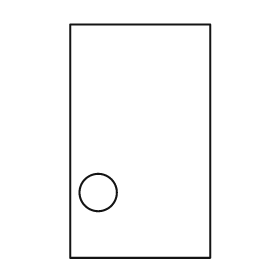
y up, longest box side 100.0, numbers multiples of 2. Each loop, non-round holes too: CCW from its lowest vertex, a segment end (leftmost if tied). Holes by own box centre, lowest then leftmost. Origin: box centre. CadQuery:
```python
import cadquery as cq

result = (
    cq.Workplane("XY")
    .moveTo(-30.0, -50.0)
    .lineTo(30.0, -50.0)
    .lineTo(30.0, 50.0)
    .lineTo(-30.0, 50.0)
    .close()
    .moveTo(-18.0, -22.0)
    .circle(8.0)
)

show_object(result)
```